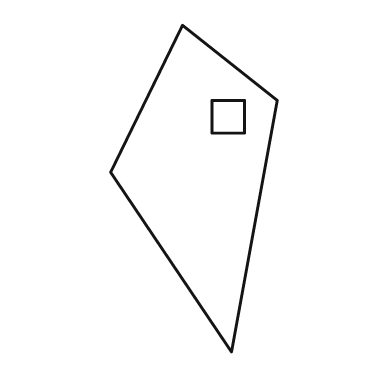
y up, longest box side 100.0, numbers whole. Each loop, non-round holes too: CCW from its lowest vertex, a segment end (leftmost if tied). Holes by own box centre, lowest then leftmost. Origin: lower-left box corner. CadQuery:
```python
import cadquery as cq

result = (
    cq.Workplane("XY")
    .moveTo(37.0, 0.0)
    .lineTo(51.0, 77.0)
    .lineTo(22.0, 100.0)
    .lineTo(0.0, 55.0)
    .close()
    .moveTo(31.0, 67.0)
    .lineTo(41.0, 67.0)
    .lineTo(41.0, 77.0)
    .lineTo(31.0, 77.0)
    .close()
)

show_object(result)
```